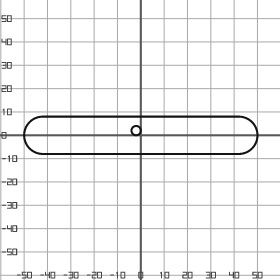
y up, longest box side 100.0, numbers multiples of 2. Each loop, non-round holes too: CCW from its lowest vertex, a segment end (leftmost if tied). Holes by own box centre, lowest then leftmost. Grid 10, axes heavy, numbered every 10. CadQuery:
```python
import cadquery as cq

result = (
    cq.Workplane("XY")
    .moveTo(-42.0, -8.0)
    .lineTo(42.0, -8.0)
    .threePointArc((50.0, 0.0), (42.0, 8.0))
    .lineTo(-42.0, 8.0)
    .threePointArc((-50.0, 0.0), (-42.0, -8.0))
    .close()
    .moveTo(-2.0, 2.0)
    .circle(2.0)
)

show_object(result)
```